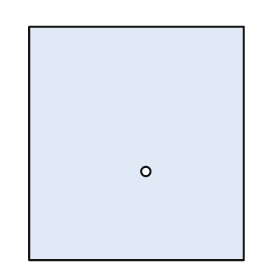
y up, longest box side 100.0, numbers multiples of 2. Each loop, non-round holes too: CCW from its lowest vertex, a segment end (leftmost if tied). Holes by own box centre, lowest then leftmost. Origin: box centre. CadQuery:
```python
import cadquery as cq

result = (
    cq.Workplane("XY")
    .moveTo(-46.0, -50.0)
    .lineTo(46.0, -50.0)
    .lineTo(46.0, 50.0)
    .lineTo(-46.0, 50.0)
    .close()
    .moveTo(4.0, -12.0)
    .circle(2.0)
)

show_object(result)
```